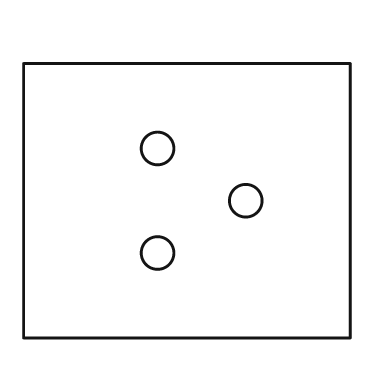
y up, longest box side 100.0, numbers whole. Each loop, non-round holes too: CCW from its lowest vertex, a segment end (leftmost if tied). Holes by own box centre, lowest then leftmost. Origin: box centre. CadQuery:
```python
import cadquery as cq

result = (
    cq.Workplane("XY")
    .moveTo(-50.0, -42.0)
    .lineTo(50.0, -42.0)
    .lineTo(50.0, 42.0)
    .lineTo(-50.0, 42.0)
    .close()
    .moveTo(-9.0, -16.0)
    .circle(5.0)
    .moveTo(18.0, 0.0)
    .circle(5.0)
    .moveTo(-9.0, 16.0)
    .circle(5.0)
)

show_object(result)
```